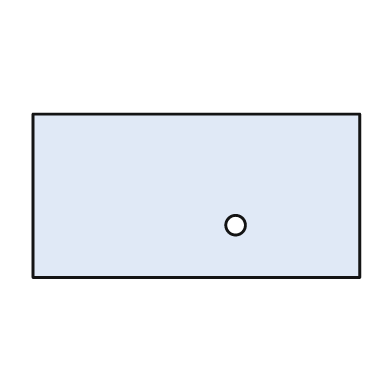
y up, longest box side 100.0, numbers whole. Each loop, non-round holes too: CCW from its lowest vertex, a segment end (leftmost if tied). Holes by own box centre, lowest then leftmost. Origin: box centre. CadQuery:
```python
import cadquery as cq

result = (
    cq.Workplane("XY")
    .moveTo(-50.0, -25.0)
    .lineTo(50.0, -25.0)
    .lineTo(50.0, 25.0)
    .lineTo(-50.0, 25.0)
    .close()
    .moveTo(12.0, -9.0)
    .circle(3.0)
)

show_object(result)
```